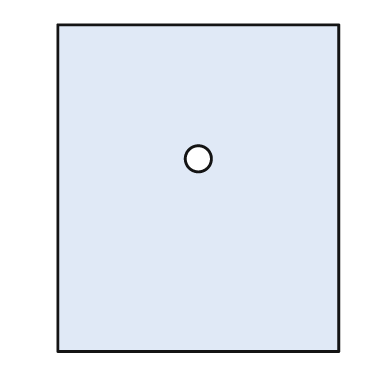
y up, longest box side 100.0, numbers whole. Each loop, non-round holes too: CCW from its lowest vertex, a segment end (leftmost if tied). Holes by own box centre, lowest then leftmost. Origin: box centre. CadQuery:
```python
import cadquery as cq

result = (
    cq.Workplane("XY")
    .moveTo(-43.0, -50.0)
    .lineTo(43.0, -50.0)
    .lineTo(43.0, 50.0)
    .lineTo(-43.0, 50.0)
    .close()
    .moveTo(0.0, 9.0)
    .circle(4.0)
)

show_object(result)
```